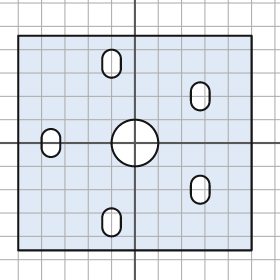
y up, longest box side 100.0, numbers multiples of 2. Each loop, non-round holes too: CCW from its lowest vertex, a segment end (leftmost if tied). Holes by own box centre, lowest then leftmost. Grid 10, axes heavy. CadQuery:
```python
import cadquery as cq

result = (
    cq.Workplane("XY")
    .moveTo(-50.0, -46.0)
    .lineTo(50.0, -46.0)
    .lineTo(50.0, 46.0)
    .lineTo(-50.0, 46.0)
    .close()
    .moveTo(-14.0, -36.0)
    .threePointArc((-10.0, -40.0), (-6.0, -36.0))
    .lineTo(-6.0, -32.0)
    .threePointArc((-10.0, -28.0), (-14.0, -32.0))
    .close()
    .moveTo(24.0, -22.0)
    .threePointArc((28.0, -26.0), (32.0, -22.0))
    .lineTo(32.0, -18.0)
    .threePointArc((28.0, -14.0), (24.0, -18.0))
    .close()
    .moveTo(-40.0, -2.0)
    .threePointArc((-36.0, -6.0), (-32.0, -2.0))
    .lineTo(-32.0, 2.0)
    .threePointArc((-36.0, 6.0), (-40.0, 2.0))
    .close()
    .moveTo(0.0, 0.0)
    .circle(10.0)
    .moveTo(24.0, 18.0)
    .threePointArc((28.0, 14.0), (32.0, 18.0))
    .lineTo(32.0, 22.0)
    .threePointArc((28.0, 26.0), (24.0, 22.0))
    .close()
    .moveTo(-14.0, 32.0)
    .threePointArc((-10.0, 28.0), (-6.0, 32.0))
    .lineTo(-6.0, 36.0)
    .threePointArc((-10.0, 40.0), (-14.0, 36.0))
    .close()
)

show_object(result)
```